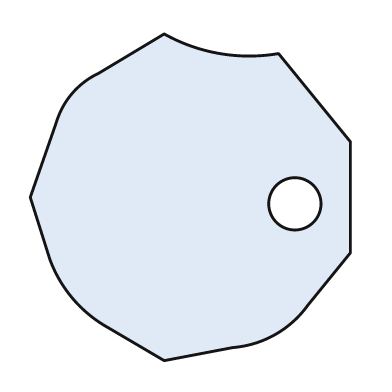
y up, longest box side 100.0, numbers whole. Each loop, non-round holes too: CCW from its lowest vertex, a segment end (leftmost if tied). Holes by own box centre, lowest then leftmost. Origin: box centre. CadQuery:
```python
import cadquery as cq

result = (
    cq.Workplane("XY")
    .moveTo(-8.0, -50.0)
    .lineTo(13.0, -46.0)
    .threePointArc((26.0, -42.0), (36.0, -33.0))
    .lineTo(49.0, -17.0)
    .lineTo(49.0, 17.0)
    .lineTo(27.0, 44.0)
    .threePointArc((9.0, 44.0), (-8.0, 50.0))
    .lineTo(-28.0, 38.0)
    .threePointArc((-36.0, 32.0), (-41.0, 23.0))
    .lineTo(-49.0, 0.0)
    .lineTo(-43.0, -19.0)
    .threePointArc((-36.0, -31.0), (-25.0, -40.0))
    .close()
    .moveTo(32.0, -2.0)
    .circle(8.0)
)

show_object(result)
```